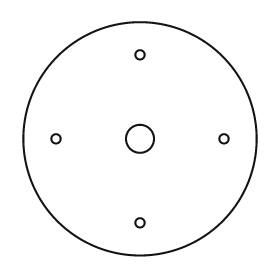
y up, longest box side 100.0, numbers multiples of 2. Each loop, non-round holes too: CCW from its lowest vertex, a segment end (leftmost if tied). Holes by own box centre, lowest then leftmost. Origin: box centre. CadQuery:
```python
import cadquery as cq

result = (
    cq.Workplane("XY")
    .moveTo(0.0, 0.0)
    .circle(50.0)
    .moveTo(0.0, -36.0)
    .circle(2.0)
    .moveTo(-36.0, 0.0)
    .circle(2.0)
    .moveTo(0.0, 0.0)
    .circle(6.0)
    .moveTo(36.0, 0.0)
    .circle(2.0)
    .moveTo(0.0, 36.0)
    .circle(2.0)
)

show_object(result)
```